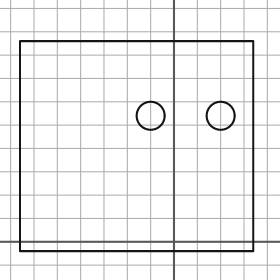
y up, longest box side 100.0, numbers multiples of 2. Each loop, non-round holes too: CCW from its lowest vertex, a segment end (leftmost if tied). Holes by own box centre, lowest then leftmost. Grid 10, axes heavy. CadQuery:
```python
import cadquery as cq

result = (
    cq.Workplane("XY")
    .moveTo(-66.0, -4.0)
    .lineTo(34.0, -4.0)
    .lineTo(34.0, 86.0)
    .lineTo(-66.0, 86.0)
    .close()
    .moveTo(-10.0, 54.0)
    .circle(6.0)
    .moveTo(20.0, 54.0)
    .circle(6.0)
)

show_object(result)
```